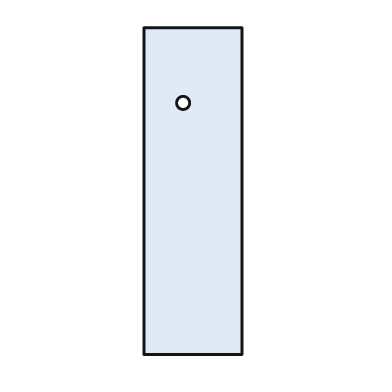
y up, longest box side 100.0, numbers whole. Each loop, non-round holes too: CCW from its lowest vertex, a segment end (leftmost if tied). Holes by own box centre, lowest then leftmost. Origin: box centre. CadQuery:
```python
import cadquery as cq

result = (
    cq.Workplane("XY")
    .moveTo(-15.0, -50.0)
    .lineTo(15.0, -50.0)
    .lineTo(15.0, 50.0)
    .lineTo(-15.0, 50.0)
    .close()
    .moveTo(-3.0, 27.0)
    .circle(2.0)
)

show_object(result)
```